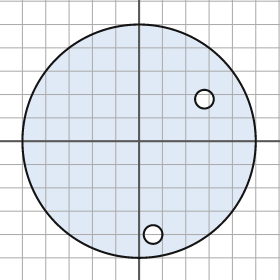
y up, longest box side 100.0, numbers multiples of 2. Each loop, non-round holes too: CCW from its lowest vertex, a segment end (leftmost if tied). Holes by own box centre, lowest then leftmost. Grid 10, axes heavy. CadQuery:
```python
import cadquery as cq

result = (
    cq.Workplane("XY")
    .moveTo(0.0, 0.0)
    .circle(50.0)
    .moveTo(6.0, -40.0)
    .circle(4.0)
    .moveTo(28.0, 18.0)
    .circle(4.0)
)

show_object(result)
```